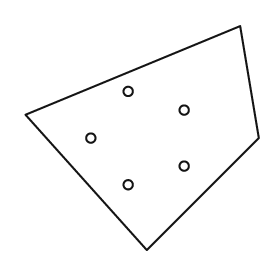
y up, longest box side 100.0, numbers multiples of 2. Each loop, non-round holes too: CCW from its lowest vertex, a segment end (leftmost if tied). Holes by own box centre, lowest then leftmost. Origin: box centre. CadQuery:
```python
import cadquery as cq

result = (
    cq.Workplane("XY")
    .moveTo(2.0, -48.0)
    .lineTo(50.0, 0.0)
    .lineTo(42.0, 48.0)
    .lineTo(-50.0, 10.0)
    .close()
    .moveTo(-6.0, -20.0)
    .circle(2.0)
    .moveTo(18.0, -12.0)
    .circle(2.0)
    .moveTo(-22.0, 0.0)
    .circle(2.0)
    .moveTo(18.0, 12.0)
    .circle(2.0)
    .moveTo(-6.0, 20.0)
    .circle(2.0)
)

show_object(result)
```